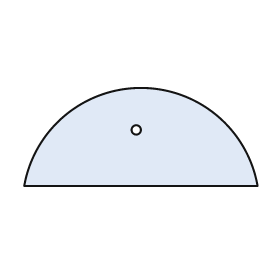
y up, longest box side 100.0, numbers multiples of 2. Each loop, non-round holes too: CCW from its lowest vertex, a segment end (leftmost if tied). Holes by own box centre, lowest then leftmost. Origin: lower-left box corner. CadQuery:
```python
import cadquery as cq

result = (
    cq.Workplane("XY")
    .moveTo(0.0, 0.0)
    .lineTo(100.0, 0.0)
    .threePointArc((50.0, 42.0), (0.0, 0.0))
    .close()
    .moveTo(48.0, 24.0)
    .circle(2.0)
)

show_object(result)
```